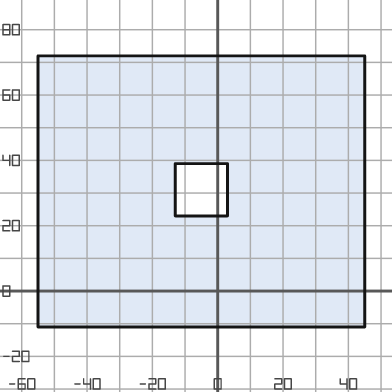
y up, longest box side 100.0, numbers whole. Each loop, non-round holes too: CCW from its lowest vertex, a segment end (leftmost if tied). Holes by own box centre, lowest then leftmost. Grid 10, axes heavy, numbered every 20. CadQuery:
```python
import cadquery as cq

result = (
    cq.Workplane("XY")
    .moveTo(-55.0, -11.0)
    .lineTo(45.0, -11.0)
    .lineTo(45.0, 72.0)
    .lineTo(-55.0, 72.0)
    .close()
    .moveTo(-13.0, 23.0)
    .lineTo(3.0, 23.0)
    .lineTo(3.0, 39.0)
    .lineTo(-13.0, 39.0)
    .close()
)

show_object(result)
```